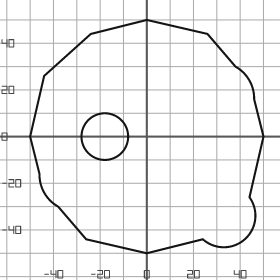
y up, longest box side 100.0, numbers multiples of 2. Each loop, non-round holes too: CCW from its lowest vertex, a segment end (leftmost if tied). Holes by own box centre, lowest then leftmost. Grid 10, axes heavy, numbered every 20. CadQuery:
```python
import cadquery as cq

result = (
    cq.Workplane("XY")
    .moveTo(0.0, -50.0)
    .lineTo(24.0, -44.0)
    .threePointArc((42.0, -44.0), (44.0, -26.0))
    .lineTo(50.0, 0.0)
    .lineTo(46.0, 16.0)
    .threePointArc((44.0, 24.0), (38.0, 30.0))
    .lineTo(26.0, 44.0)
    .lineTo(0.0, 50.0)
    .lineTo(-24.0, 44.0)
    .lineTo(-44.0, 26.0)
    .lineTo(-50.0, 0.0)
    .lineTo(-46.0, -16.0)
    .threePointArc((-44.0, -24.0), (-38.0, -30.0))
    .lineTo(-26.0, -44.0)
    .close()
    .moveTo(-18.0, 0.0)
    .circle(10.0)
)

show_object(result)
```